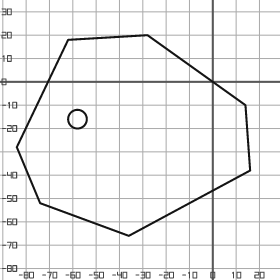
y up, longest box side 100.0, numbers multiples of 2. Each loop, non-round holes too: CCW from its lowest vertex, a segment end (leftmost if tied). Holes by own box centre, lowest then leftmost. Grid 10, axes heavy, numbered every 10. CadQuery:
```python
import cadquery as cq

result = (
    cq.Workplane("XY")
    .moveTo(-36.0, -66.0)
    .lineTo(16.0, -38.0)
    .lineTo(14.0, -10.0)
    .lineTo(-28.0, 20.0)
    .lineTo(-62.0, 18.0)
    .lineTo(-84.0, -28.0)
    .lineTo(-74.0, -52.0)
    .close()
    .moveTo(-58.0, -16.0)
    .circle(4.0)
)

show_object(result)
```